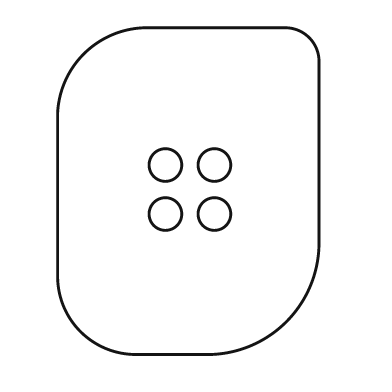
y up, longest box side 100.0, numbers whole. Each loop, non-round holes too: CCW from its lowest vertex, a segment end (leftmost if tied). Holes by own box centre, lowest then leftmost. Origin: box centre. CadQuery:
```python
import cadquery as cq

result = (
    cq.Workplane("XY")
    .moveTo(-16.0, -50.0)
    .lineTo(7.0, -50.0)
    .threePointArc((30.0, -40.0), (40.0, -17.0))
    .lineTo(40.0, 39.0)
    .threePointArc((37.0, 47.0), (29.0, 50.0))
    .lineTo(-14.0, 50.0)
    .threePointArc((-32.0, 42.0), (-40.0, 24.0))
    .lineTo(-40.0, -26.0)
    .threePointArc((-33.0, -43.0), (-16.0, -50.0))
    .close()
    .moveTo(-7.0, -7.0)
    .circle(5.0)
    .moveTo(8.0, -7.0)
    .circle(5.0)
    .moveTo(-7.0, 8.0)
    .circle(5.0)
    .moveTo(8.0, 8.0)
    .circle(5.0)
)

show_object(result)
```